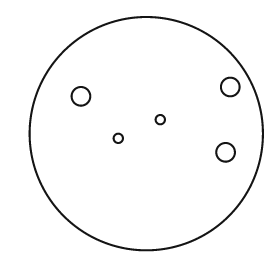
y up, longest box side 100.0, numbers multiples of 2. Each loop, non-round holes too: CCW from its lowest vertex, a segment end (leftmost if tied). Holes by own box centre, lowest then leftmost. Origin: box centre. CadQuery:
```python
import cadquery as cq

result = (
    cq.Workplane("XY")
    .moveTo(0.0, 0.0)
    .circle(50.0)
    .moveTo(34.0, -8.0)
    .circle(4.0)
    .moveTo(-12.0, -2.0)
    .circle(2.0)
    .moveTo(6.0, 6.0)
    .circle(2.0)
    .moveTo(-28.0, 16.0)
    .circle(4.0)
    .moveTo(36.0, 20.0)
    .circle(4.0)
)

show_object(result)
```